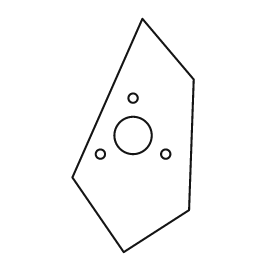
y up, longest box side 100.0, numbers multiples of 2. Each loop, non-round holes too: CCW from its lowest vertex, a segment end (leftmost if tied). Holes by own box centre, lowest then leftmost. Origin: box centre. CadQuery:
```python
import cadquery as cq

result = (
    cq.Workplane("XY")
    .moveTo(-4.0, -50.0)
    .lineTo(24.0, -32.0)
    .lineTo(26.0, 24.0)
    .lineTo(4.0, 50.0)
    .lineTo(-26.0, -18.0)
    .close()
    .moveTo(-14.0, -8.0)
    .circle(2.0)
    .moveTo(14.0, -8.0)
    .circle(2.0)
    .moveTo(0.0, 0.0)
    .circle(8.0)
    .moveTo(0.0, 16.0)
    .circle(2.0)
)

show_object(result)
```